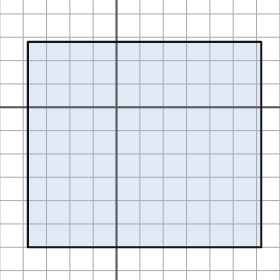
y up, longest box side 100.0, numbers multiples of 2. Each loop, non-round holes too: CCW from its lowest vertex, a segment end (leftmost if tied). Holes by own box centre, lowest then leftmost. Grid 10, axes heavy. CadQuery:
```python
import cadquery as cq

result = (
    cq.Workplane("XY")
    .moveTo(-38.0, -60.0)
    .lineTo(62.0, -60.0)
    .lineTo(62.0, 28.0)
    .lineTo(-38.0, 28.0)
    .close()
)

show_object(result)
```